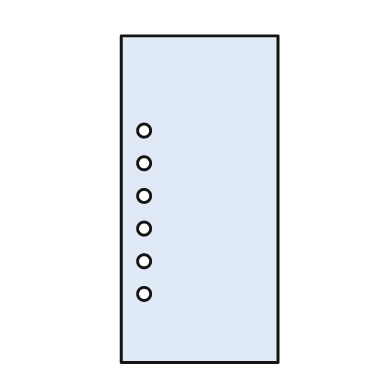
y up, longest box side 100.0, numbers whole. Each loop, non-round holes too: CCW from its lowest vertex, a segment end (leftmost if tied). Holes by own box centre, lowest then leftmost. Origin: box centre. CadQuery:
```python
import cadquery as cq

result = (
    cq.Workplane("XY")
    .moveTo(-24.0, -50.0)
    .lineTo(24.0, -50.0)
    .lineTo(24.0, 50.0)
    .lineTo(-24.0, 50.0)
    .close()
    .moveTo(-17.0, -29.0)
    .circle(2.0)
    .moveTo(-17.0, -19.0)
    .circle(2.0)
    .moveTo(-17.0, -9.0)
    .circle(2.0)
    .moveTo(-17.0, 1.0)
    .circle(2.0)
    .moveTo(-17.0, 11.0)
    .circle(2.0)
    .moveTo(-17.0, 21.0)
    .circle(2.0)
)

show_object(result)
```